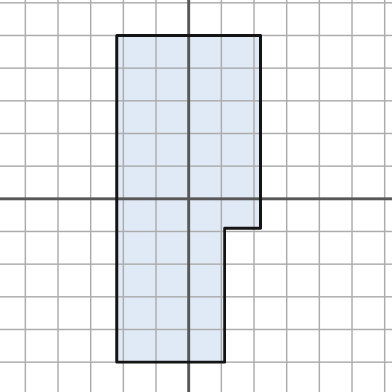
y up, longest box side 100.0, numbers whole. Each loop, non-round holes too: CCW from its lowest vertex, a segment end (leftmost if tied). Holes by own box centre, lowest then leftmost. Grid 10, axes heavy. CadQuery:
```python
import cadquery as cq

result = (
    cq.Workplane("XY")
    .moveTo(-22.0, -50.0)
    .lineTo(11.0, -50.0)
    .lineTo(11.0, -9.0)
    .lineTo(22.0, -9.0)
    .lineTo(22.0, 50.0)
    .lineTo(-22.0, 50.0)
    .close()
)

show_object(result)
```